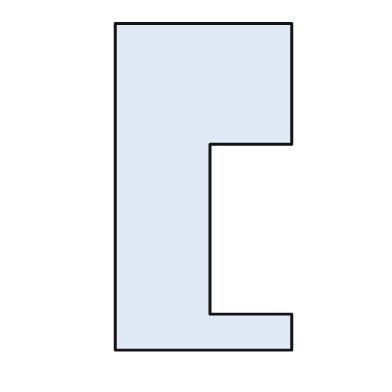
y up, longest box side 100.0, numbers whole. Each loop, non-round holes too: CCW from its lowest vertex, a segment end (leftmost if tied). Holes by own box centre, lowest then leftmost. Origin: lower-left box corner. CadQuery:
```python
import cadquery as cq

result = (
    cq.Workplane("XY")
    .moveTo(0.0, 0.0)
    .lineTo(54.0, 0.0)
    .lineTo(54.0, 11.0)
    .lineTo(29.0, 11.0)
    .lineTo(29.0, 63.0)
    .lineTo(54.0, 63.0)
    .lineTo(54.0, 100.0)
    .lineTo(0.0, 100.0)
    .close()
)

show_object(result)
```